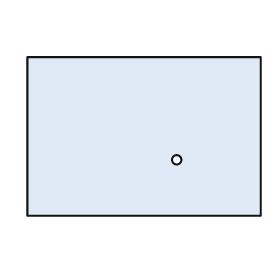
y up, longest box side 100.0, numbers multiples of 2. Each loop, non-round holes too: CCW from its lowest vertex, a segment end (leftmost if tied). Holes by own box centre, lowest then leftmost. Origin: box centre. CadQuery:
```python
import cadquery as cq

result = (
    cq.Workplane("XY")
    .moveTo(-50.0, -34.0)
    .lineTo(50.0, -34.0)
    .lineTo(50.0, 34.0)
    .lineTo(-50.0, 34.0)
    .close()
    .moveTo(14.0, -10.0)
    .circle(2.0)
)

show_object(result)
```